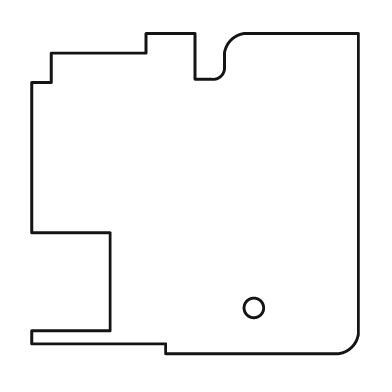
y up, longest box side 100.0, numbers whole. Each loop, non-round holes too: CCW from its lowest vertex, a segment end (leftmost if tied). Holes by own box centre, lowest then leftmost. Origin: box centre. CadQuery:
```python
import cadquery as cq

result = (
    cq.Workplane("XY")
    .moveTo(-9.0, -49.0)
    .lineTo(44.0, -49.0)
    .threePointArc((48.0, -47.0), (50.0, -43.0))
    .lineTo(50.0, 49.0)
    .lineTo(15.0, 49.0)
    .threePointArc((11.0, 47.0), (9.0, 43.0))
    .lineTo(9.0, 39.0)
    .threePointArc((8.0, 36.0), (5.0, 35.0))
    .lineTo(0.0, 35.0)
    .lineTo(0.0, 49.0)
    .lineTo(-15.0, 49.0)
    .lineTo(-15.0, 43.0)
    .lineTo(-44.0, 43.0)
    .lineTo(-44.0, 34.0)
    .lineTo(-50.0, 34.0)
    .lineTo(-50.0, -12.0)
    .lineTo(-26.0, -12.0)
    .lineTo(-26.0, -42.0)
    .lineTo(-50.0, -42.0)
    .lineTo(-50.0, -46.0)
    .lineTo(-9.0, -46.0)
    .close()
    .moveTo(18.0, -35.0)
    .circle(3.0)
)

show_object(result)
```